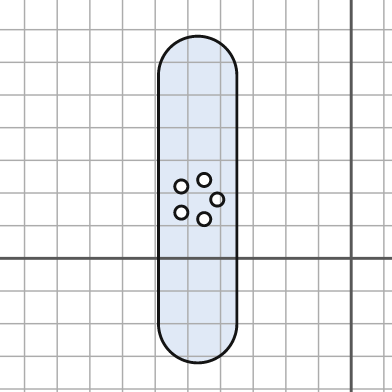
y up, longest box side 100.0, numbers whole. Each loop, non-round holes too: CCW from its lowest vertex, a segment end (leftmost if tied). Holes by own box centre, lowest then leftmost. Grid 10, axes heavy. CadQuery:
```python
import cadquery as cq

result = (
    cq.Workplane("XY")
    .moveTo(-59.0, -20.0)
    .threePointArc((-47.0, -32.0), (-35.0, -20.0))
    .lineTo(-35.0, 56.0)
    .threePointArc((-47.0, 68.0), (-59.0, 56.0))
    .close()
    .moveTo(-45.0, 12.0)
    .circle(2.0)
    .moveTo(-52.0, 14.0)
    .circle(2.0)
    .moveTo(-41.0, 18.0)
    .circle(2.0)
    .moveTo(-52.0, 22.0)
    .circle(2.0)
    .moveTo(-45.0, 24.0)
    .circle(2.0)
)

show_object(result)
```